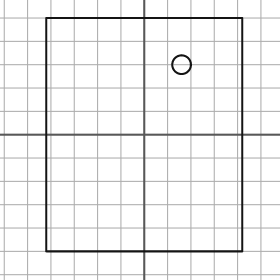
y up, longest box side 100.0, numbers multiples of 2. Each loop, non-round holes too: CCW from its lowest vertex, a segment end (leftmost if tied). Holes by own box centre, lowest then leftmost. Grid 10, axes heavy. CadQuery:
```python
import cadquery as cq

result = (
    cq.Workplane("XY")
    .moveTo(-42.0, -50.0)
    .lineTo(42.0, -50.0)
    .lineTo(42.0, 50.0)
    .lineTo(-42.0, 50.0)
    .close()
    .moveTo(16.0, 30.0)
    .circle(4.0)
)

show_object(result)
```